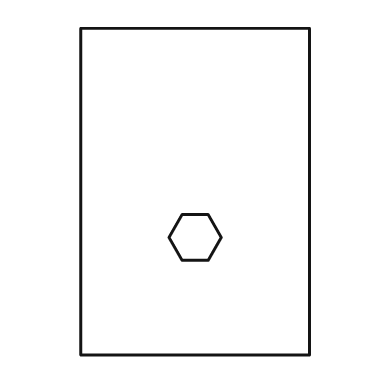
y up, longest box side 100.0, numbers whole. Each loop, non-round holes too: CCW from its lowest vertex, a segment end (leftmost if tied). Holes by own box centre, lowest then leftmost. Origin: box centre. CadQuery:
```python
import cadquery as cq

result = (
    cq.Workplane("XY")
    .moveTo(-35.0, -50.0)
    .lineTo(35.0, -50.0)
    .lineTo(35.0, 50.0)
    .lineTo(-35.0, 50.0)
    .close()
    .moveTo(-4.0, -21.0)
    .lineTo(4.0, -21.0)
    .lineTo(8.0, -14.0)
    .lineTo(4.0, -7.0)
    .lineTo(-4.0, -7.0)
    .lineTo(-8.0, -14.0)
    .close()
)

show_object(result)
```